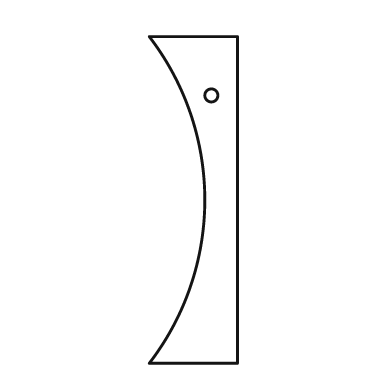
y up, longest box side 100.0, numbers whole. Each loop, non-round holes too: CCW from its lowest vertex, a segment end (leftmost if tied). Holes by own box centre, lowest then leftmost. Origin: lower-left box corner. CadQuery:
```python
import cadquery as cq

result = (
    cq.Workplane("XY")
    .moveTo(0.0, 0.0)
    .lineTo(27.0, 0.0)
    .lineTo(27.0, 100.0)
    .lineTo(0.0, 100.0)
    .threePointArc((17.0, 50.0), (0.0, 0.0))
    .close()
    .moveTo(19.0, 82.0)
    .circle(2.0)
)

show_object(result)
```